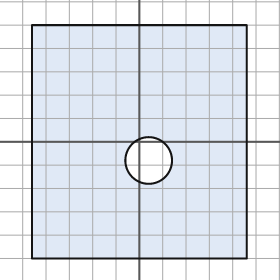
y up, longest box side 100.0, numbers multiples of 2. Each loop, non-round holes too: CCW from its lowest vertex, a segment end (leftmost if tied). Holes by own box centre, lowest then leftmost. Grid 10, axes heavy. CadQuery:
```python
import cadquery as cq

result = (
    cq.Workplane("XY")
    .moveTo(-46.0, -50.0)
    .lineTo(46.0, -50.0)
    .lineTo(46.0, 50.0)
    .lineTo(-46.0, 50.0)
    .close()
    .moveTo(4.0, -8.0)
    .circle(10.0)
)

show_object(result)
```